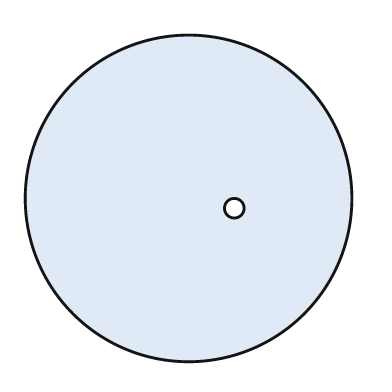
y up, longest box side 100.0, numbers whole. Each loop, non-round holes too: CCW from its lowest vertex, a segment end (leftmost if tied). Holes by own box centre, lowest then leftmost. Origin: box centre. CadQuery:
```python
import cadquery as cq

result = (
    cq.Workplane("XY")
    .moveTo(0.0, 0.0)
    .circle(50.0)
    .moveTo(14.0, -3.0)
    .circle(3.0)
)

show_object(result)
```